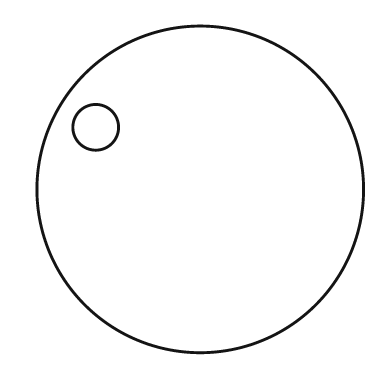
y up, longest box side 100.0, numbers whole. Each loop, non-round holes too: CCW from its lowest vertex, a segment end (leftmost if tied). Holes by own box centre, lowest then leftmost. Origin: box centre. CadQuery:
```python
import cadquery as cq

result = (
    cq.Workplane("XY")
    .moveTo(0.0, 0.0)
    .circle(50.0)
    .moveTo(-32.0, 19.0)
    .circle(7.0)
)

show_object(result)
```